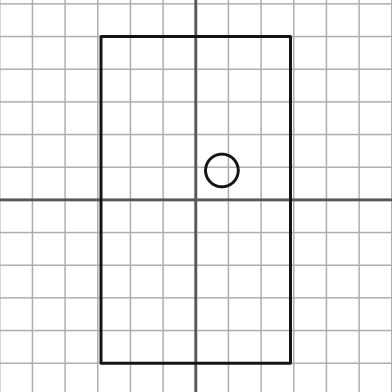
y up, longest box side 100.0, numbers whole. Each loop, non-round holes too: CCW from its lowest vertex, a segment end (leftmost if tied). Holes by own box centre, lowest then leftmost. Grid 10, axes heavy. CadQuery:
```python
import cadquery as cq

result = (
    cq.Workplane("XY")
    .moveTo(-29.0, -50.0)
    .lineTo(29.0, -50.0)
    .lineTo(29.0, 50.0)
    .lineTo(-29.0, 50.0)
    .close()
    .moveTo(8.0, 9.0)
    .circle(5.0)
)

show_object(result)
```